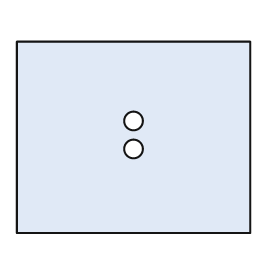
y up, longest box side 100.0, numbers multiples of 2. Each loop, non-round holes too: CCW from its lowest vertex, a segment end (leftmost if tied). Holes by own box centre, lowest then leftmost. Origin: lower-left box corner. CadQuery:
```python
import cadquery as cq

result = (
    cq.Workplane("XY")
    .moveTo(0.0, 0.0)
    .lineTo(100.0, 0.0)
    .lineTo(100.0, 82.0)
    .lineTo(0.0, 82.0)
    .close()
    .moveTo(50.0, 36.0)
    .circle(4.0)
    .moveTo(50.0, 48.0)
    .circle(4.0)
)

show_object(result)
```